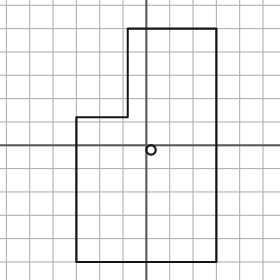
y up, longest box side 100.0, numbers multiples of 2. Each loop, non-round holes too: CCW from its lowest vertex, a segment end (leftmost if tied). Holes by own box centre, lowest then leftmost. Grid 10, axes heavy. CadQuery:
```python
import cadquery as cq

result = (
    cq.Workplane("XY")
    .moveTo(-30.0, -50.0)
    .lineTo(30.0, -50.0)
    .lineTo(30.0, 50.0)
    .lineTo(-8.0, 50.0)
    .lineTo(-8.0, 12.0)
    .lineTo(-30.0, 12.0)
    .close()
    .moveTo(2.0, -2.0)
    .circle(2.0)
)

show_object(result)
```